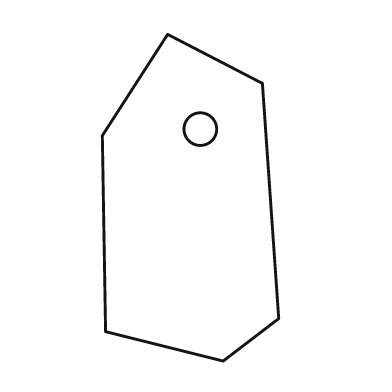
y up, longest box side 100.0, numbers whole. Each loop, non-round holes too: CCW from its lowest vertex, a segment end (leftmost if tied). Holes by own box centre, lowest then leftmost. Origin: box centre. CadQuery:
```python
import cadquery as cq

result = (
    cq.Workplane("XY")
    .moveTo(10.0, -50.0)
    .lineTo(27.0, -37.0)
    .lineTo(22.0, 35.0)
    .lineTo(-7.0, 50.0)
    .lineTo(-27.0, 19.0)
    .lineTo(-26.0, -41.0)
    .close()
    .moveTo(3.0, 21.0)
    .circle(5.0)
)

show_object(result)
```